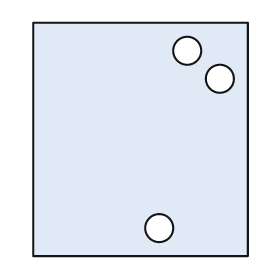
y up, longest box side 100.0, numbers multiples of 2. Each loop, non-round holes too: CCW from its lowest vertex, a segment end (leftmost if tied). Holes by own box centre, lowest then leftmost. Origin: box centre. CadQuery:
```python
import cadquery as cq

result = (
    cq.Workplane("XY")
    .moveTo(-46.0, -50.0)
    .lineTo(46.0, -50.0)
    .lineTo(46.0, 50.0)
    .lineTo(-46.0, 50.0)
    .close()
    .moveTo(8.0, -38.0)
    .circle(6.0)
    .moveTo(34.0, 26.0)
    .circle(6.0)
    .moveTo(20.0, 38.0)
    .circle(6.0)
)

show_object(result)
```